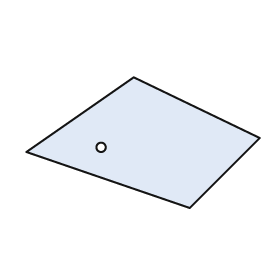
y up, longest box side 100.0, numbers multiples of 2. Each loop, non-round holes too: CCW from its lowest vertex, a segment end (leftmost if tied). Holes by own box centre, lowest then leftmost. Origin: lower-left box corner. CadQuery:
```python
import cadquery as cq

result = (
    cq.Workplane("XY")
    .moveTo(70.0, 0.0)
    .lineTo(100.0, 30.0)
    .lineTo(46.0, 56.0)
    .lineTo(0.0, 24.0)
    .close()
    .moveTo(32.0, 26.0)
    .circle(2.0)
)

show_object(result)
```